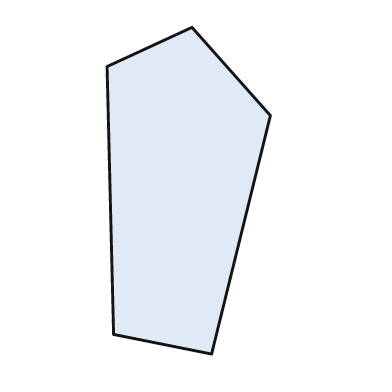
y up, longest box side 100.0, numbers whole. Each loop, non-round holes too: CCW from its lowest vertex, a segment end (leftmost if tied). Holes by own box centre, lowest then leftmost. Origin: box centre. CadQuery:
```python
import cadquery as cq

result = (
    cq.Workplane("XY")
    .moveTo(7.0, -50.0)
    .lineTo(25.0, 23.0)
    .lineTo(1.0, 50.0)
    .lineTo(-25.0, 38.0)
    .lineTo(-23.0, -44.0)
    .close()
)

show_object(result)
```